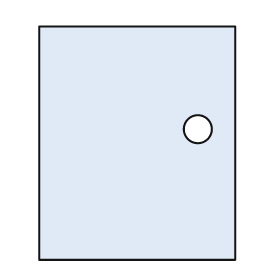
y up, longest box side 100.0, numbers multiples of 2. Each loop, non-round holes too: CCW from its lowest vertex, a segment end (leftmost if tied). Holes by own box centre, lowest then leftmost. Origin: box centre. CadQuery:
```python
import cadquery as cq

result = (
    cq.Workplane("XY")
    .moveTo(-42.0, -50.0)
    .lineTo(42.0, -50.0)
    .lineTo(42.0, 50.0)
    .lineTo(-42.0, 50.0)
    .close()
    .moveTo(26.0, 6.0)
    .circle(6.0)
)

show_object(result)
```